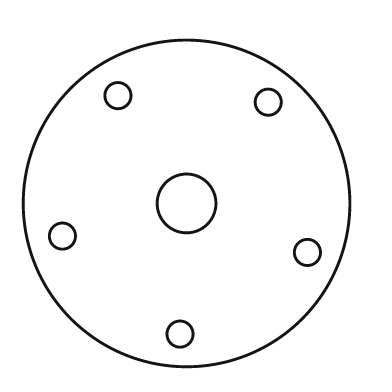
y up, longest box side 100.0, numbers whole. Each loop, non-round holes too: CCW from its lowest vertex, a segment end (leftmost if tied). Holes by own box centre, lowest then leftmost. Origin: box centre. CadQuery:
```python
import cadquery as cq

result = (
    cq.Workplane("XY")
    .moveTo(0.0, 0.0)
    .circle(50.0)
    .moveTo(-2.0, -40.0)
    .circle(4.0)
    .moveTo(37.0, -15.0)
    .circle(4.0)
    .moveTo(-38.0, -10.0)
    .circle(4.0)
    .moveTo(0.0, 0.0)
    .circle(9.0)
    .moveTo(25.0, 31.0)
    .circle(4.0)
    .moveTo(-21.0, 33.0)
    .circle(4.0)
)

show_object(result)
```